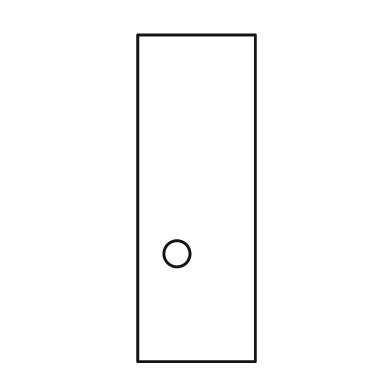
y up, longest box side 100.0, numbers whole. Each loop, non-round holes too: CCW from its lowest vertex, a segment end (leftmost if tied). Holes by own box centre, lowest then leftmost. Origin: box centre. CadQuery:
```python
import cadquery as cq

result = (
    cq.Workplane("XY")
    .moveTo(-18.0, -50.0)
    .lineTo(18.0, -50.0)
    .lineTo(18.0, 50.0)
    .lineTo(-18.0, 50.0)
    .close()
    .moveTo(-6.0, -17.0)
    .circle(4.0)
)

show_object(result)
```